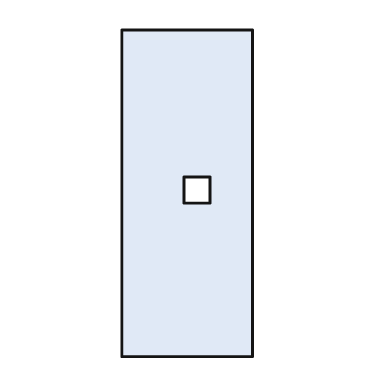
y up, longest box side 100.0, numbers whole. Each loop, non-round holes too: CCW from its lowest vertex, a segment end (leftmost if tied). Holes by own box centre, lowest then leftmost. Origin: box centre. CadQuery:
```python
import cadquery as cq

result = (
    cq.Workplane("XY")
    .moveTo(-20.0, -50.0)
    .lineTo(20.0, -50.0)
    .lineTo(20.0, 50.0)
    .lineTo(-20.0, 50.0)
    .close()
    .moveTo(-1.0, -3.0)
    .lineTo(7.0, -3.0)
    .lineTo(7.0, 5.0)
    .lineTo(-1.0, 5.0)
    .close()
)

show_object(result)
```